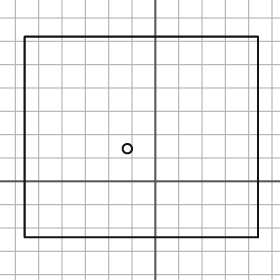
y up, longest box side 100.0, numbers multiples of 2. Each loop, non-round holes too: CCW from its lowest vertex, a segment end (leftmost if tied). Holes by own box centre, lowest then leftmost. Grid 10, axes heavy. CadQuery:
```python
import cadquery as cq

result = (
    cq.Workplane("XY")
    .moveTo(-56.0, -24.0)
    .lineTo(44.0, -24.0)
    .lineTo(44.0, 62.0)
    .lineTo(-56.0, 62.0)
    .close()
    .moveTo(-12.0, 14.0)
    .circle(2.0)
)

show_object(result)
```